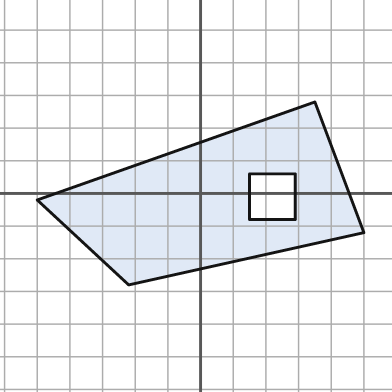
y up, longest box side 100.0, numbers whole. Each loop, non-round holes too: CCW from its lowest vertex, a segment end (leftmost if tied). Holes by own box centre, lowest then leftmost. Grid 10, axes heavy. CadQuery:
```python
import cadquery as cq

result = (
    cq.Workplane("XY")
    .moveTo(-22.0, -28.0)
    .lineTo(50.0, -12.0)
    .lineTo(35.0, 28.0)
    .lineTo(-50.0, -2.0)
    .close()
    .moveTo(15.0, -8.0)
    .lineTo(29.0, -8.0)
    .lineTo(29.0, 6.0)
    .lineTo(15.0, 6.0)
    .close()
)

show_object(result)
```